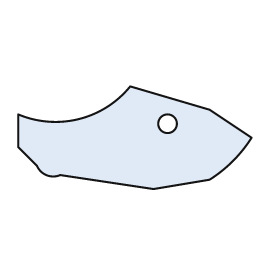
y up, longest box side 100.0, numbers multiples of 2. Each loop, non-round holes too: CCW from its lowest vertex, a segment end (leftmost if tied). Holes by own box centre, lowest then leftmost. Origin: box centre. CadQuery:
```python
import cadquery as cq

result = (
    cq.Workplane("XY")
    .moveTo(8.0, -22.0)
    .lineTo(32.0, -18.0)
    .threePointArc((42.0, -10.0), (50.0, 0.0))
    .lineTo(32.0, 12.0)
    .lineTo(-2.0, 22.0)
    .threePointArc((-24.0, 8.0), (-50.0, 10.0))
    .lineTo(-50.0, -4.0)
    .lineTo(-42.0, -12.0)
    .threePointArc((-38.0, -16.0), (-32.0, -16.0))
    .close()
    .moveTo(14.0, 6.0)
    .circle(4.0)
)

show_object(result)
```